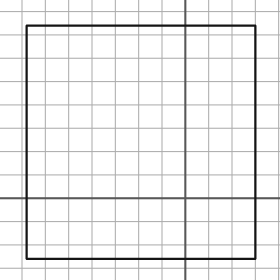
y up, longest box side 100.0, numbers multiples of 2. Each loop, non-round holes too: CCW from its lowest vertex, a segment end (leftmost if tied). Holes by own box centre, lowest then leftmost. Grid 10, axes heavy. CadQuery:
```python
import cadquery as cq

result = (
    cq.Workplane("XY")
    .moveTo(-68.0, -26.0)
    .lineTo(30.0, -26.0)
    .lineTo(30.0, 74.0)
    .lineTo(-68.0, 74.0)
    .close()
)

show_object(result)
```